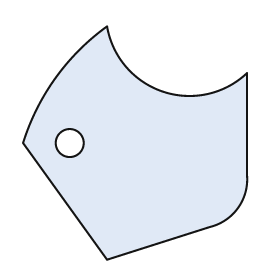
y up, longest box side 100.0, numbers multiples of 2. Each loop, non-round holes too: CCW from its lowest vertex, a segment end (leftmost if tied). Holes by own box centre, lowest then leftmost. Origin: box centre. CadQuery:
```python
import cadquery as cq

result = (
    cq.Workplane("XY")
    .moveTo(-12.0, -50.0)
    .lineTo(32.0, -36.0)
    .threePointArc((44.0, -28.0), (48.0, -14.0))
    .lineTo(48.0, 30.0)
    .threePointArc((12.0, 22.0), (-12.0, 50.0))
    .threePointArc((-34.0, 28.0), (-48.0, 0.0))
    .close()
    .moveTo(-28.0, 0.0)
    .circle(6.0)
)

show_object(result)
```